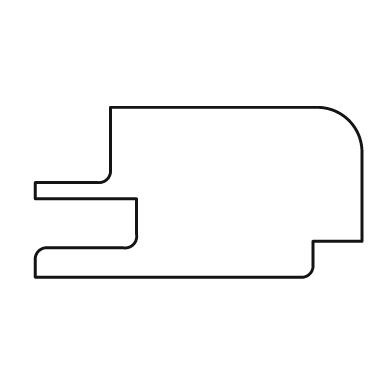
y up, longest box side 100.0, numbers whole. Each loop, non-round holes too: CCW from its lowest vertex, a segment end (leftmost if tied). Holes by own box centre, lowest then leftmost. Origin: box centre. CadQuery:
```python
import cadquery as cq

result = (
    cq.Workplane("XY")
    .moveTo(-50.0, -26.0)
    .lineTo(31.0, -26.0)
    .threePointArc((34.0, -25.0), (35.0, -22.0))
    .lineTo(35.0, -15.0)
    .lineTo(50.0, -15.0)
    .lineTo(50.0, 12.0)
    .threePointArc((46.0, 22.0), (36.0, 26.0))
    .lineTo(-27.0, 26.0)
    .lineTo(-27.0, 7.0)
    .threePointArc((-28.0, 4.0), (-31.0, 3.0))
    .lineTo(-50.0, 3.0)
    .lineTo(-50.0, -2.0)
    .lineTo(-19.0, -2.0)
    .lineTo(-19.0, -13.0)
    .threePointArc((-20.0, -16.0), (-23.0, -17.0))
    .lineTo(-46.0, -17.0)
    .threePointArc((-49.0, -18.0), (-50.0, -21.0))
    .close()
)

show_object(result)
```